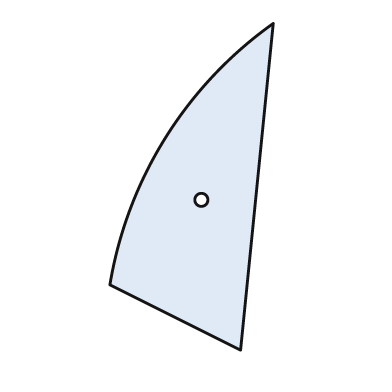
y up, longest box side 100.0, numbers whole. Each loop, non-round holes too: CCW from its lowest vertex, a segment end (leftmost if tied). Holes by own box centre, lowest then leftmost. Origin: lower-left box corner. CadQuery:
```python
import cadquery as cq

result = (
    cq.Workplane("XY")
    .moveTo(40.0, 0.0)
    .lineTo(50.0, 100.0)
    .threePointArc((17.0, 65.0), (0.0, 20.0))
    .close()
    .moveTo(28.0, 46.0)
    .circle(2.0)
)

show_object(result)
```